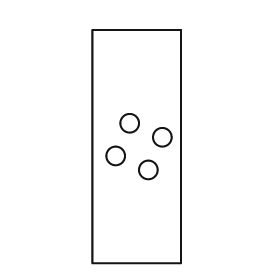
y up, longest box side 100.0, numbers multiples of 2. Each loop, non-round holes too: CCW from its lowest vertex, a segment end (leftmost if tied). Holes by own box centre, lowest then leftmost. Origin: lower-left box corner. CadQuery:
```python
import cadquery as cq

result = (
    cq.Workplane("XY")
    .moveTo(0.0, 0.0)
    .lineTo(38.0, 0.0)
    .lineTo(38.0, 100.0)
    .lineTo(0.0, 100.0)
    .close()
    .moveTo(24.0, 40.0)
    .circle(4.0)
    .moveTo(10.0, 46.0)
    .circle(4.0)
    .moveTo(30.0, 54.0)
    .circle(4.0)
    .moveTo(16.0, 60.0)
    .circle(4.0)
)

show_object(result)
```